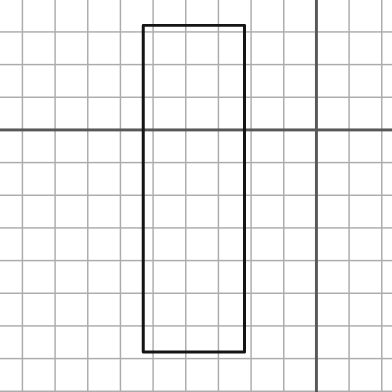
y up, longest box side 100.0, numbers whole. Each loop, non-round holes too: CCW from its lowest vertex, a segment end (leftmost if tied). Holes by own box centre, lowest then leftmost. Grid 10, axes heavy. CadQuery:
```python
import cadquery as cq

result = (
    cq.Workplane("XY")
    .moveTo(-53.0, -68.0)
    .lineTo(-22.0, -68.0)
    .lineTo(-22.0, 32.0)
    .lineTo(-53.0, 32.0)
    .close()
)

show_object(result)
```